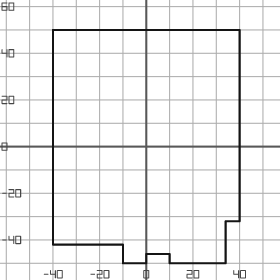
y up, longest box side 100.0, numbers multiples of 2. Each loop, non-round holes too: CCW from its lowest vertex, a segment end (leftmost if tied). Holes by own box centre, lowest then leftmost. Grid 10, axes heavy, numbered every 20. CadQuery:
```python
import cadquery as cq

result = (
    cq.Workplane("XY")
    .moveTo(-10.0, -50.0)
    .lineTo(0.0, -50.0)
    .lineTo(0.0, -46.0)
    .lineTo(10.0, -46.0)
    .lineTo(10.0, -50.0)
    .lineTo(34.0, -50.0)
    .lineTo(34.0, -32.0)
    .lineTo(40.0, -32.0)
    .lineTo(40.0, 50.0)
    .lineTo(-40.0, 50.0)
    .lineTo(-40.0, -42.0)
    .lineTo(-10.0, -42.0)
    .close()
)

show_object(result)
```